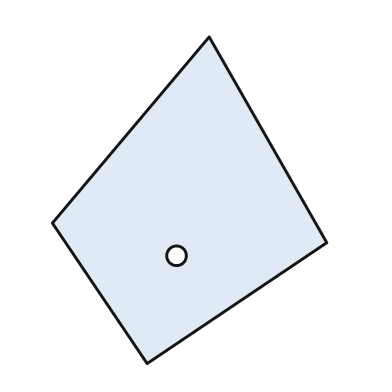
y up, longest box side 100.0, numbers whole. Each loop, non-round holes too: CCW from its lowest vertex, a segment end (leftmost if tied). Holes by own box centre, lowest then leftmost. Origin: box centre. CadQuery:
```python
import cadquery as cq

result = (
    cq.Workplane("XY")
    .moveTo(-13.0, -50.0)
    .lineTo(42.0, -13.0)
    .lineTo(6.0, 50.0)
    .lineTo(-42.0, -7.0)
    .close()
    .moveTo(-4.0, -17.0)
    .circle(3.0)
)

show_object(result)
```